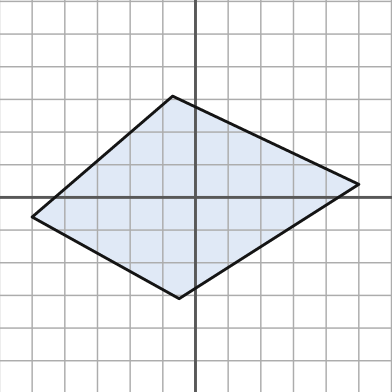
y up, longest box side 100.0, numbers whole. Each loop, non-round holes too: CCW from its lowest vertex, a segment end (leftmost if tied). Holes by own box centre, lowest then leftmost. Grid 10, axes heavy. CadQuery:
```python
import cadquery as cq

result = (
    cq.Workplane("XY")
    .moveTo(-5.0, -31.0)
    .lineTo(50.0, 4.0)
    .lineTo(-7.0, 31.0)
    .lineTo(-50.0, -6.0)
    .close()
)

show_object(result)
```